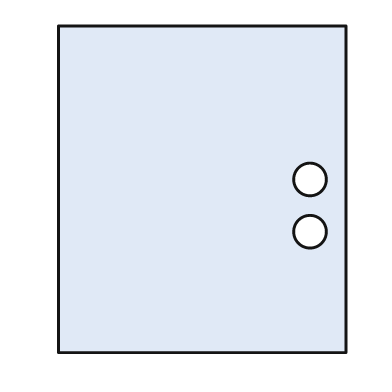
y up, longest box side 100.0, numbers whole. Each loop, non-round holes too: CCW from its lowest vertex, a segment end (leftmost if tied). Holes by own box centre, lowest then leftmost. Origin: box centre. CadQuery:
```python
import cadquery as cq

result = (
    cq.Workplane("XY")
    .moveTo(-44.0, -50.0)
    .lineTo(44.0, -50.0)
    .lineTo(44.0, 50.0)
    .lineTo(-44.0, 50.0)
    .close()
    .moveTo(33.0, -13.0)
    .circle(5.0)
    .moveTo(33.0, 3.0)
    .circle(5.0)
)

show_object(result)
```